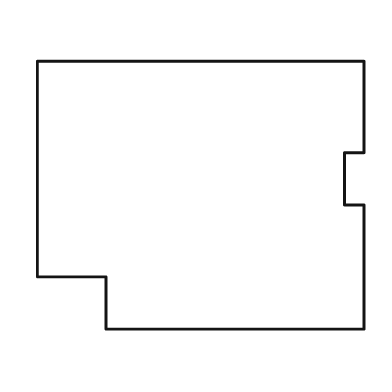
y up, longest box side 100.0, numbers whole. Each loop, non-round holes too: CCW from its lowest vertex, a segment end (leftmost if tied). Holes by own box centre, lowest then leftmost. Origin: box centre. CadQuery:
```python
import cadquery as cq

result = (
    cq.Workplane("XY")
    .moveTo(-29.0, -41.0)
    .lineTo(50.0, -41.0)
    .lineTo(50.0, -3.0)
    .lineTo(44.0, -3.0)
    .lineTo(44.0, 13.0)
    .lineTo(50.0, 13.0)
    .lineTo(50.0, 41.0)
    .lineTo(-50.0, 41.0)
    .lineTo(-50.0, -25.0)
    .lineTo(-29.0, -25.0)
    .close()
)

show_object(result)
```